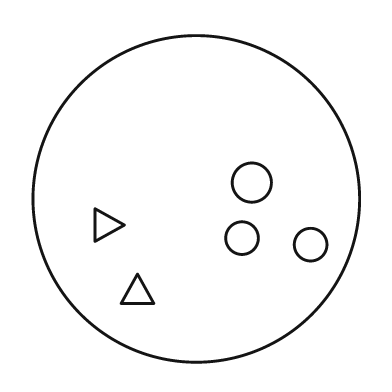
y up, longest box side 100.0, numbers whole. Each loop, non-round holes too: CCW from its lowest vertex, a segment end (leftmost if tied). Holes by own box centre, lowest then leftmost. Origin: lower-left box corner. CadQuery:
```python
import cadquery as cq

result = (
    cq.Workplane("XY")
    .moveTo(50.0, 50.0)
    .circle(50.0)
    .moveTo(27.0, 18.0)
    .lineTo(37.0, 18.0)
    .lineTo(32.0, 27.0)
    .close()
    .moveTo(85.0, 36.0)
    .circle(5.0)
    .moveTo(64.0, 38.0)
    .circle(5.0)
    .moveTo(19.0, 37.0)
    .lineTo(28.0, 42.0)
    .lineTo(19.0, 47.0)
    .close()
    .moveTo(67.0, 55.0)
    .circle(6.0)
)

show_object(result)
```